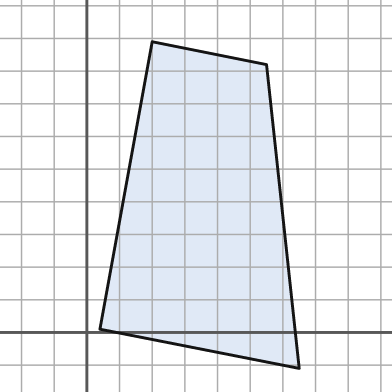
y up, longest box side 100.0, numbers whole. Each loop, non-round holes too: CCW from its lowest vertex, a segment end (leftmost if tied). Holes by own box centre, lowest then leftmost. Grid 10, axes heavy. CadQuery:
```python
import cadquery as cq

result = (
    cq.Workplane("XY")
    .moveTo(65.0, -11.0)
    .lineTo(55.0, 82.0)
    .lineTo(20.0, 89.0)
    .lineTo(4.0, 1.0)
    .close()
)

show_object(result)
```